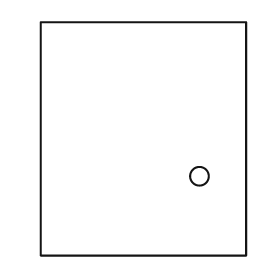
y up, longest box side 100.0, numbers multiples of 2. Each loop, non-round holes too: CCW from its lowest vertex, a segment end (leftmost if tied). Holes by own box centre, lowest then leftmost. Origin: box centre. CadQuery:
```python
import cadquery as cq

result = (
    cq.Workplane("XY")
    .moveTo(-44.0, -50.0)
    .lineTo(44.0, -50.0)
    .lineTo(44.0, 50.0)
    .lineTo(-44.0, 50.0)
    .close()
    .moveTo(24.0, -16.0)
    .circle(4.0)
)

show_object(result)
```